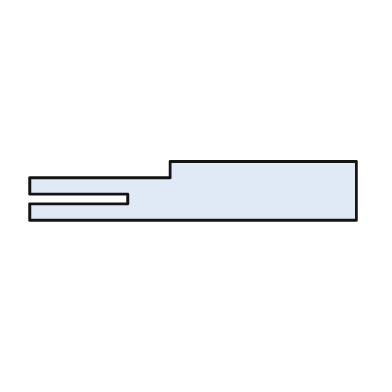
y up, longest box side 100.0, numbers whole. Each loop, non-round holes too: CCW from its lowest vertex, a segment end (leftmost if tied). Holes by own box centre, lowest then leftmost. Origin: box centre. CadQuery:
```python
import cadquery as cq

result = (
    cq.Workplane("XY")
    .moveTo(-50.0, -9.0)
    .lineTo(50.0, -9.0)
    .lineTo(50.0, 9.0)
    .lineTo(-7.0, 9.0)
    .lineTo(-7.0, 4.0)
    .lineTo(-50.0, 4.0)
    .lineTo(-50.0, -1.0)
    .lineTo(-20.0, -1.0)
    .lineTo(-20.0, -4.0)
    .lineTo(-50.0, -4.0)
    .close()
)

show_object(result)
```